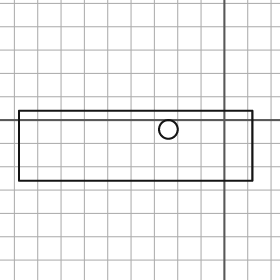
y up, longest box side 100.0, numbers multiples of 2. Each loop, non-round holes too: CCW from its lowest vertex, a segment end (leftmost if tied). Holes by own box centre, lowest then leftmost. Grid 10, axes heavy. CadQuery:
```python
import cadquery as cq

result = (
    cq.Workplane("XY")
    .moveTo(-88.0, -26.0)
    .lineTo(12.0, -26.0)
    .lineTo(12.0, 4.0)
    .lineTo(-88.0, 4.0)
    .close()
    .moveTo(-24.0, -4.0)
    .circle(4.0)
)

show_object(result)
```